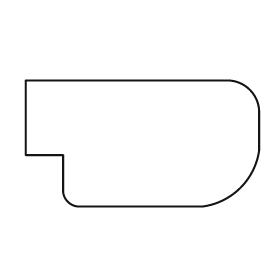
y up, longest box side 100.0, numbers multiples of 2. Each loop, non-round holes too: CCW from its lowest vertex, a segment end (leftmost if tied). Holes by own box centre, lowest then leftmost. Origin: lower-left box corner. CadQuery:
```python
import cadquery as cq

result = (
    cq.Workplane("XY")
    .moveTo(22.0, 0.0)
    .lineTo(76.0, 0.0)
    .threePointArc((92.0, 8.0), (100.0, 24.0))
    .lineTo(100.0, 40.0)
    .threePointArc((96.0, 50.0), (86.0, 54.0))
    .lineTo(0.0, 54.0)
    .lineTo(0.0, 22.0)
    .lineTo(16.0, 22.0)
    .lineTo(16.0, 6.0)
    .threePointArc((18.0, 2.0), (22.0, 0.0))
    .close()
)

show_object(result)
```